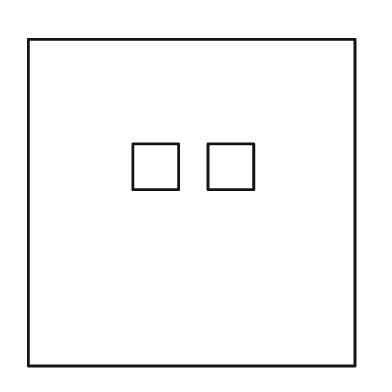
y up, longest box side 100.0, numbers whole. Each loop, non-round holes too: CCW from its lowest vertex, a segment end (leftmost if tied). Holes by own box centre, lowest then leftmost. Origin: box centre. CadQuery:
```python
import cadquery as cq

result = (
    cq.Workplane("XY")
    .moveTo(-50.0, -50.0)
    .lineTo(50.0, -50.0)
    .lineTo(50.0, 50.0)
    .lineTo(-50.0, 50.0)
    .close()
    .moveTo(-18.0, 4.0)
    .lineTo(-4.0, 4.0)
    .lineTo(-4.0, 18.0)
    .lineTo(-18.0, 18.0)
    .close()
    .moveTo(5.0, 4.0)
    .lineTo(19.0, 4.0)
    .lineTo(19.0, 18.0)
    .lineTo(5.0, 18.0)
    .close()
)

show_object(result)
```